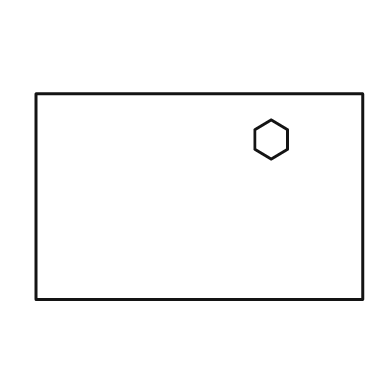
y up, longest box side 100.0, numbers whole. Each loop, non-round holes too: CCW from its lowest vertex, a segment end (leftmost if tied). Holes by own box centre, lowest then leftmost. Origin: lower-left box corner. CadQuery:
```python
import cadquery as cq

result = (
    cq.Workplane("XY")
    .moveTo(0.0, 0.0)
    .lineTo(100.0, 0.0)
    .lineTo(100.0, 63.0)
    .lineTo(0.0, 63.0)
    .close()
    .moveTo(72.0, 43.0)
    .lineTo(77.0, 46.0)
    .lineTo(77.0, 52.0)
    .lineTo(72.0, 55.0)
    .lineTo(67.0, 52.0)
    .lineTo(67.0, 46.0)
    .close()
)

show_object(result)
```